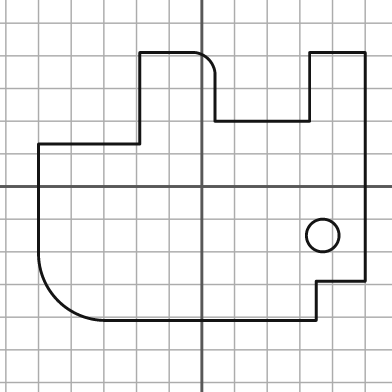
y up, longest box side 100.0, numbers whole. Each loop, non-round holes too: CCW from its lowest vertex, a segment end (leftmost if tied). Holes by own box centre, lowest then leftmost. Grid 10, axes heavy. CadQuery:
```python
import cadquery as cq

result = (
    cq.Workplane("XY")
    .moveTo(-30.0, -41.0)
    .lineTo(35.0, -41.0)
    .lineTo(35.0, -29.0)
    .lineTo(50.0, -29.0)
    .lineTo(50.0, 41.0)
    .lineTo(33.0, 41.0)
    .lineTo(33.0, 20.0)
    .lineTo(4.0, 20.0)
    .lineTo(4.0, 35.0)
    .threePointArc((2.0, 39.0), (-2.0, 41.0))
    .lineTo(-19.0, 41.0)
    .lineTo(-19.0, 13.0)
    .lineTo(-50.0, 13.0)
    .lineTo(-50.0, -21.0)
    .threePointArc((-44.0, -35.0), (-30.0, -41.0))
    .close()
    .moveTo(37.0, -15.0)
    .circle(5.0)
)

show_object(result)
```